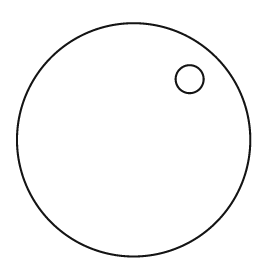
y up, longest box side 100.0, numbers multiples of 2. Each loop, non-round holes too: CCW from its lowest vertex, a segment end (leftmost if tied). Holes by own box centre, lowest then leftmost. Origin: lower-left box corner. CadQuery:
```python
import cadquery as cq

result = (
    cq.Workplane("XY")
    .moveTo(50.0, 50.0)
    .circle(50.0)
    .moveTo(74.0, 76.0)
    .circle(6.0)
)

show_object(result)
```